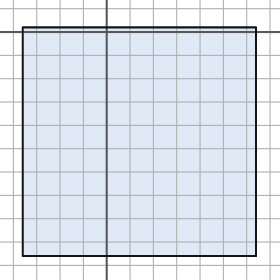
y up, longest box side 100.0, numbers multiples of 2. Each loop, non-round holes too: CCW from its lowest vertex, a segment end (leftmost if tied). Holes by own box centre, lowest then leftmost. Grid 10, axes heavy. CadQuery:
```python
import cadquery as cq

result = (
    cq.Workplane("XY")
    .moveTo(-36.0, -96.0)
    .lineTo(64.0, -96.0)
    .lineTo(64.0, 2.0)
    .lineTo(-36.0, 2.0)
    .close()
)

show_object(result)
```